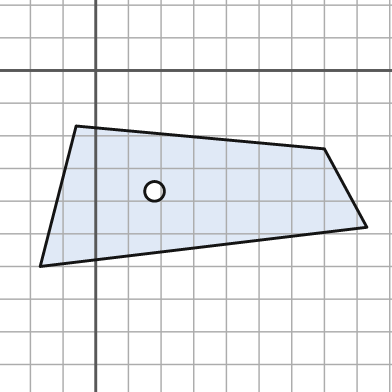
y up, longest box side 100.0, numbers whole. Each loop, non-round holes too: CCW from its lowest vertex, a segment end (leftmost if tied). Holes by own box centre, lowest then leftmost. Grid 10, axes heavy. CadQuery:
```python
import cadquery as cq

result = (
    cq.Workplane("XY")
    .moveTo(-17.0, -60.0)
    .lineTo(83.0, -48.0)
    .lineTo(70.0, -24.0)
    .lineTo(-6.0, -17.0)
    .close()
    .moveTo(18.0, -37.0)
    .circle(3.0)
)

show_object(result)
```